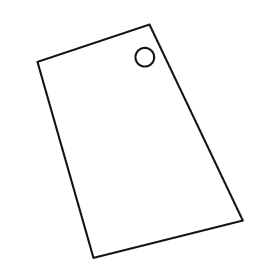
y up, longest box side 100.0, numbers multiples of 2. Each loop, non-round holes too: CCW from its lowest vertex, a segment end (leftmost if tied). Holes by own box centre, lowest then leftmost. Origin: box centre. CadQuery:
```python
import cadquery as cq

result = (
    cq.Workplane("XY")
    .moveTo(-20.0, -50.0)
    .lineTo(44.0, -34.0)
    .lineTo(4.0, 50.0)
    .lineTo(-44.0, 34.0)
    .close()
    .moveTo(2.0, 36.0)
    .circle(4.0)
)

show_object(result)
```